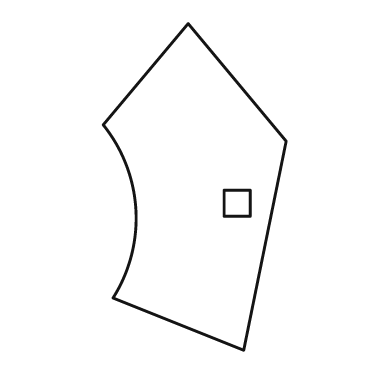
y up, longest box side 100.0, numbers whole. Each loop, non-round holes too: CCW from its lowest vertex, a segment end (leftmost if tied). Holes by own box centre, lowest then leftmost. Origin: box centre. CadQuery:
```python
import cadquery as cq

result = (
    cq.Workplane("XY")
    .moveTo(15.0, -50.0)
    .lineTo(28.0, 14.0)
    .lineTo(-2.0, 50.0)
    .lineTo(-28.0, 19.0)
    .threePointArc((-18.0, -7.0), (-25.0, -34.0))
    .close()
    .moveTo(9.0, -9.0)
    .lineTo(17.0, -9.0)
    .lineTo(17.0, -1.0)
    .lineTo(9.0, -1.0)
    .close()
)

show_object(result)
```